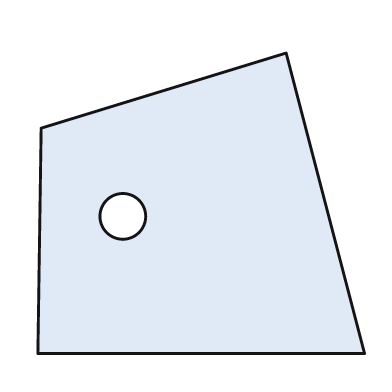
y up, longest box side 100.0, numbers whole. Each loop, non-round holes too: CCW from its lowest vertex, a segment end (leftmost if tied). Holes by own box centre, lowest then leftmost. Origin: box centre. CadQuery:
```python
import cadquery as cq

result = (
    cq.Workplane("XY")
    .moveTo(-50.0, -46.0)
    .lineTo(50.0, -46.0)
    .lineTo(26.0, 46.0)
    .lineTo(-49.0, 23.0)
    .close()
    .moveTo(-24.0, -4.0)
    .circle(7.0)
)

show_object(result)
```